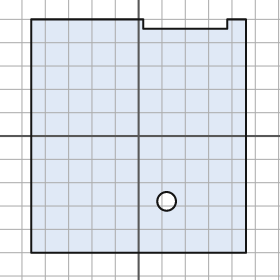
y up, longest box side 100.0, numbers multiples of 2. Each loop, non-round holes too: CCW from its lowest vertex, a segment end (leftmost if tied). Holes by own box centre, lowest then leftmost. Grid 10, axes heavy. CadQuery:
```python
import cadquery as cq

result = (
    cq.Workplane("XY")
    .moveTo(-46.0, -50.0)
    .lineTo(46.0, -50.0)
    .lineTo(46.0, 50.0)
    .lineTo(38.0, 50.0)
    .lineTo(38.0, 46.0)
    .lineTo(2.0, 46.0)
    .lineTo(2.0, 50.0)
    .lineTo(-46.0, 50.0)
    .close()
    .moveTo(12.0, -28.0)
    .circle(4.0)
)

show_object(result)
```